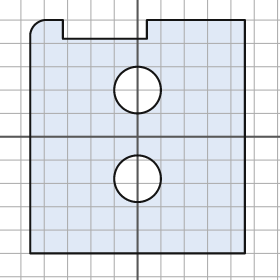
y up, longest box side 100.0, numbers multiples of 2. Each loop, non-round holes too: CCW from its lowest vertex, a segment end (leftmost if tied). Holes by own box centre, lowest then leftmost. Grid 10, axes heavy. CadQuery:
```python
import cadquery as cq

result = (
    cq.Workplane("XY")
    .moveTo(-46.0, -50.0)
    .lineTo(46.0, -50.0)
    .lineTo(46.0, 50.0)
    .lineTo(4.0, 50.0)
    .lineTo(4.0, 42.0)
    .lineTo(-32.0, 42.0)
    .lineTo(-32.0, 50.0)
    .lineTo(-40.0, 50.0)
    .threePointArc((-44.0, 48.0), (-46.0, 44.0))
    .close()
    .moveTo(0.0, -18.0)
    .circle(10.0)
    .moveTo(0.0, 20.0)
    .circle(10.0)
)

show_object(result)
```